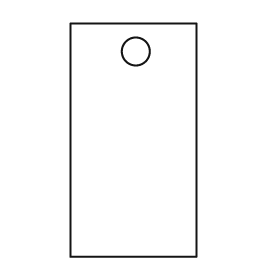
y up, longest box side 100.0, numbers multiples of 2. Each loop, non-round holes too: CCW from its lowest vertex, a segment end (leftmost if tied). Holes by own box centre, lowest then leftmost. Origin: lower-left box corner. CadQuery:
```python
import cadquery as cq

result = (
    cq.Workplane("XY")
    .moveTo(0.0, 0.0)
    .lineTo(54.0, 0.0)
    .lineTo(54.0, 100.0)
    .lineTo(0.0, 100.0)
    .close()
    .moveTo(28.0, 88.0)
    .circle(6.0)
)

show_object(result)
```